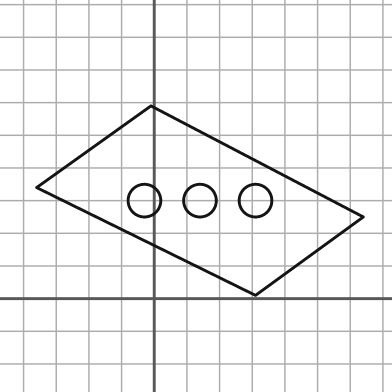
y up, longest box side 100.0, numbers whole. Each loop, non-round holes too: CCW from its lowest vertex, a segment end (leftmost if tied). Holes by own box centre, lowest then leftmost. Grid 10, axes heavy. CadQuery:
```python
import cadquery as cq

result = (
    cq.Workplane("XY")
    .moveTo(31.0, 1.0)
    .lineTo(64.0, 25.0)
    .lineTo(-1.0, 59.0)
    .lineTo(-36.0, 34.0)
    .close()
    .moveTo(-3.0, 30.0)
    .circle(5.0)
    .moveTo(14.0, 30.0)
    .circle(5.0)
    .moveTo(31.0, 30.0)
    .circle(5.0)
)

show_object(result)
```